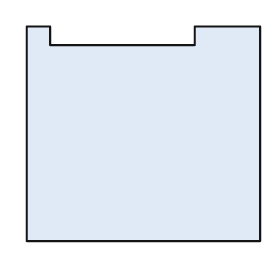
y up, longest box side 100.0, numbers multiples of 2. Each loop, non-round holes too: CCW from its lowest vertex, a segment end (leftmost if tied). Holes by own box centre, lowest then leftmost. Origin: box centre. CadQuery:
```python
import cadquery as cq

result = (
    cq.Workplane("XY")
    .moveTo(-50.0, -46.0)
    .lineTo(50.0, -46.0)
    .lineTo(50.0, 46.0)
    .lineTo(22.0, 46.0)
    .lineTo(22.0, 38.0)
    .lineTo(-40.0, 38.0)
    .lineTo(-40.0, 46.0)
    .lineTo(-50.0, 46.0)
    .close()
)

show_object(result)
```